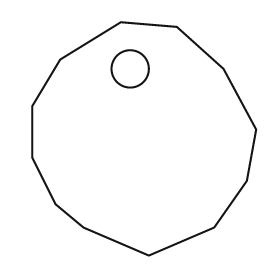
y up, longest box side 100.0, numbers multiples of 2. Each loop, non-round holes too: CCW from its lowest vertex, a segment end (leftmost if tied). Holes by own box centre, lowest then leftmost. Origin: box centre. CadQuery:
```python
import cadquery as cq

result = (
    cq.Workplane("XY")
    .moveTo(2.0, -50.0)
    .lineTo(30.0, -38.0)
    .lineTo(44.0, -18.0)
    .lineTo(48.0, 4.0)
    .lineTo(34.0, 30.0)
    .lineTo(14.0, 48.0)
    .lineTo(-10.0, 50.0)
    .lineTo(-36.0, 34.0)
    .lineTo(-48.0, 14.0)
    .lineTo(-48.0, -8.0)
    .lineTo(-38.0, -28.0)
    .lineTo(-26.0, -38.0)
    .close()
    .moveTo(-6.0, 30.0)
    .circle(8.0)
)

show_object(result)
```